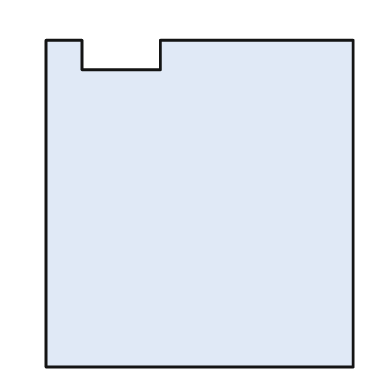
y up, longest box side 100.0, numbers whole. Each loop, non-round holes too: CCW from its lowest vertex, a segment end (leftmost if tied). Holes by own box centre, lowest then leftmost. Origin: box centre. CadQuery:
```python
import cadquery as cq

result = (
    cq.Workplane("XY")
    .moveTo(-47.0, -50.0)
    .lineTo(47.0, -50.0)
    .lineTo(47.0, 50.0)
    .lineTo(-12.0, 50.0)
    .lineTo(-12.0, 41.0)
    .lineTo(-36.0, 41.0)
    .lineTo(-36.0, 50.0)
    .lineTo(-47.0, 50.0)
    .close()
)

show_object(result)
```